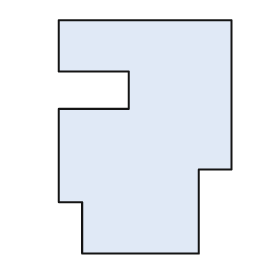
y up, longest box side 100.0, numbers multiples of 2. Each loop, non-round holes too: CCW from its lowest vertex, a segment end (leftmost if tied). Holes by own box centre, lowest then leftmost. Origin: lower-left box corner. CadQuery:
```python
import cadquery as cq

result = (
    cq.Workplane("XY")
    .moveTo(10.0, 0.0)
    .lineTo(60.0, 0.0)
    .lineTo(60.0, 36.0)
    .lineTo(74.0, 36.0)
    .lineTo(74.0, 100.0)
    .lineTo(0.0, 100.0)
    .lineTo(0.0, 78.0)
    .lineTo(30.0, 78.0)
    .lineTo(30.0, 62.0)
    .lineTo(0.0, 62.0)
    .lineTo(0.0, 22.0)
    .lineTo(10.0, 22.0)
    .close()
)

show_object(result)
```